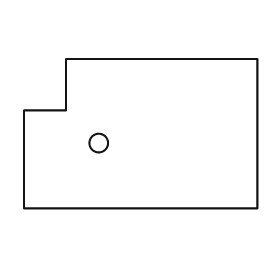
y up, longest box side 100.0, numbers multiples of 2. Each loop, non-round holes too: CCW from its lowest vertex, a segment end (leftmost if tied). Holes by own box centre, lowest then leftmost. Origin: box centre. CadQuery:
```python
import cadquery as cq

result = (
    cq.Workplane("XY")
    .moveTo(-50.0, -32.0)
    .lineTo(50.0, -32.0)
    .lineTo(50.0, 32.0)
    .lineTo(-32.0, 32.0)
    .lineTo(-32.0, 10.0)
    .lineTo(-50.0, 10.0)
    .close()
    .moveTo(-18.0, -4.0)
    .circle(4.0)
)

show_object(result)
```